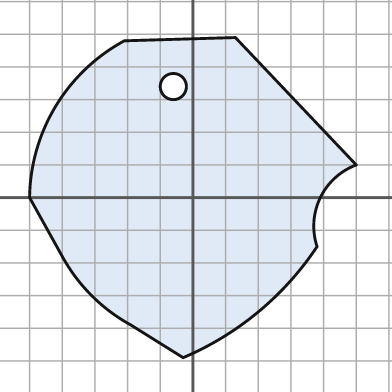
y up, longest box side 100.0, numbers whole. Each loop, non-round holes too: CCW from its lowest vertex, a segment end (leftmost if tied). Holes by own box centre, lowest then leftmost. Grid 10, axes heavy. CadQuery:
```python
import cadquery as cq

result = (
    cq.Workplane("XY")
    .moveTo(-3.0, -49.0)
    .threePointArc((20.0, -35.0), (38.0, -15.0))
    .threePointArc((39.0, 0.0), (50.0, 10.0))
    .lineTo(13.0, 49.0)
    .lineTo(-21.0, 48.0)
    .threePointArc((-42.0, 28.0), (-50.0, 0.0))
    .lineTo(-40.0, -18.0)
    .threePointArc((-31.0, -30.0), (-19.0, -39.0))
    .close()
    .moveTo(-6.0, 34.0)
    .circle(4.0)
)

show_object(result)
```